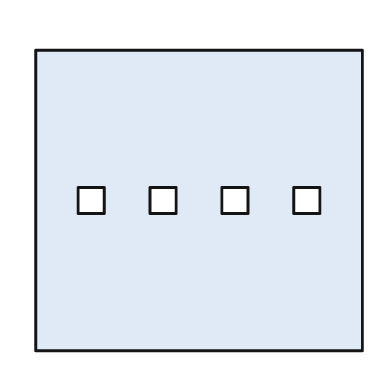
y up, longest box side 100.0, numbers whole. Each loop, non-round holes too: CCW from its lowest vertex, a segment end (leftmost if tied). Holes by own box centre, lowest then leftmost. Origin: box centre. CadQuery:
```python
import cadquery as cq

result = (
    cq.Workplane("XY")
    .moveTo(-50.0, -46.0)
    .lineTo(50.0, -46.0)
    .lineTo(50.0, 46.0)
    .lineTo(-50.0, 46.0)
    .close()
    .moveTo(-37.0, -4.0)
    .lineTo(-29.0, -4.0)
    .lineTo(-29.0, 4.0)
    .lineTo(-37.0, 4.0)
    .close()
    .moveTo(-15.0, -4.0)
    .lineTo(-7.0, -4.0)
    .lineTo(-7.0, 4.0)
    .lineTo(-15.0, 4.0)
    .close()
    .moveTo(7.0, -4.0)
    .lineTo(15.0, -4.0)
    .lineTo(15.0, 4.0)
    .lineTo(7.0, 4.0)
    .close()
    .moveTo(29.0, -4.0)
    .lineTo(37.0, -4.0)
    .lineTo(37.0, 4.0)
    .lineTo(29.0, 4.0)
    .close()
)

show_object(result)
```